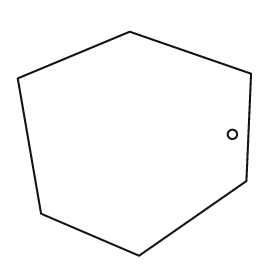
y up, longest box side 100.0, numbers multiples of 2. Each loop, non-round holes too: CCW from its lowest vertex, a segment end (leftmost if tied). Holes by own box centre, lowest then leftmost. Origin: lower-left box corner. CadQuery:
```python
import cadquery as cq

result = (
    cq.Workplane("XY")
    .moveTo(52.0, 0.0)
    .lineTo(98.0, 32.0)
    .lineTo(100.0, 78.0)
    .lineTo(48.0, 96.0)
    .lineTo(0.0, 76.0)
    .lineTo(10.0, 18.0)
    .close()
    .moveTo(92.0, 52.0)
    .circle(2.0)
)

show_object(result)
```